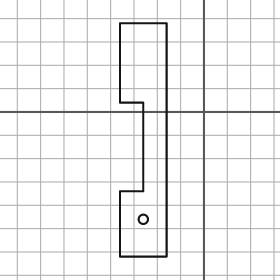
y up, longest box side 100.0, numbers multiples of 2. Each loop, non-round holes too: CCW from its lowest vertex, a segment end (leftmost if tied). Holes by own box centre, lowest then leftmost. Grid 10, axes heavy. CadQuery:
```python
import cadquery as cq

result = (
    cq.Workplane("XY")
    .moveTo(-36.0, -62.0)
    .lineTo(-16.0, -62.0)
    .lineTo(-16.0, 38.0)
    .lineTo(-36.0, 38.0)
    .lineTo(-36.0, 4.0)
    .lineTo(-26.0, 4.0)
    .lineTo(-26.0, -34.0)
    .lineTo(-36.0, -34.0)
    .close()
    .moveTo(-26.0, -46.0)
    .circle(2.0)
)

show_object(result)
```